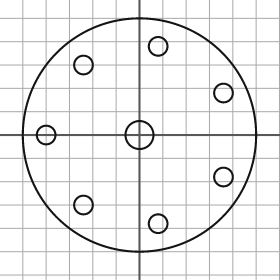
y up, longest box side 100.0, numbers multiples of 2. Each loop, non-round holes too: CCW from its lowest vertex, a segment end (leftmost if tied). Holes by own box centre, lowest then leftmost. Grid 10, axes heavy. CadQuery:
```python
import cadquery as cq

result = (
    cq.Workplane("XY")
    .moveTo(0.0, 0.0)
    .circle(50.0)
    .moveTo(8.0, -38.0)
    .circle(4.0)
    .moveTo(-24.0, -30.0)
    .circle(4.0)
    .moveTo(36.0, -18.0)
    .circle(4.0)
    .moveTo(-40.0, 0.0)
    .circle(4.0)
    .moveTo(0.0, 0.0)
    .circle(6.0)
    .moveTo(36.0, 18.0)
    .circle(4.0)
    .moveTo(-24.0, 30.0)
    .circle(4.0)
    .moveTo(8.0, 38.0)
    .circle(4.0)
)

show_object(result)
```